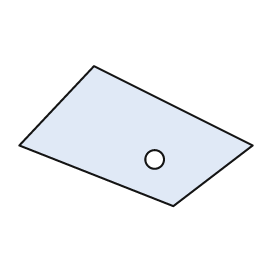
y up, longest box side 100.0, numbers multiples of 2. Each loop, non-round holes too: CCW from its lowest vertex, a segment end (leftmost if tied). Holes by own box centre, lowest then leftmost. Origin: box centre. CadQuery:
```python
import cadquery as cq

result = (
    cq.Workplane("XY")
    .moveTo(16.0, -30.0)
    .lineTo(50.0, -4.0)
    .lineTo(-18.0, 30.0)
    .lineTo(-50.0, -4.0)
    .close()
    .moveTo(8.0, -10.0)
    .circle(4.0)
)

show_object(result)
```